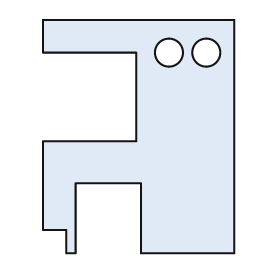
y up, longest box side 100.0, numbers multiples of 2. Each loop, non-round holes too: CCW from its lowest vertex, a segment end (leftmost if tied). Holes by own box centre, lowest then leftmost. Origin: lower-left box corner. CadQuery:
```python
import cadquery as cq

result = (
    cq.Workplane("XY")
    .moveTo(10.0, 0.0)
    .lineTo(14.0, 0.0)
    .lineTo(14.0, 30.0)
    .lineTo(42.0, 30.0)
    .lineTo(42.0, 0.0)
    .lineTo(82.0, 0.0)
    .lineTo(82.0, 100.0)
    .lineTo(0.0, 100.0)
    .lineTo(0.0, 86.0)
    .lineTo(40.0, 86.0)
    .lineTo(40.0, 48.0)
    .lineTo(0.0, 48.0)
    .lineTo(0.0, 10.0)
    .lineTo(10.0, 10.0)
    .close()
    .moveTo(54.0, 86.0)
    .circle(6.0)
    .moveTo(70.0, 86.0)
    .circle(6.0)
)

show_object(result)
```